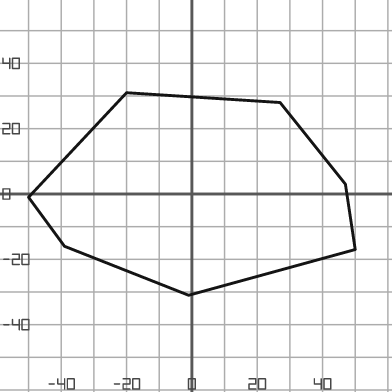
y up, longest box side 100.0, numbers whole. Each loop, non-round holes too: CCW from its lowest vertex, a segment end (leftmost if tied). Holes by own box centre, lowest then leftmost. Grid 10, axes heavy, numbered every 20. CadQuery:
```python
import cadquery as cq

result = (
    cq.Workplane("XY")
    .moveTo(-1.0, -31.0)
    .lineTo(50.0, -17.0)
    .lineTo(47.0, 3.0)
    .lineTo(27.0, 28.0)
    .lineTo(-20.0, 31.0)
    .lineTo(-50.0, -1.0)
    .lineTo(-39.0, -16.0)
    .close()
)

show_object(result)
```